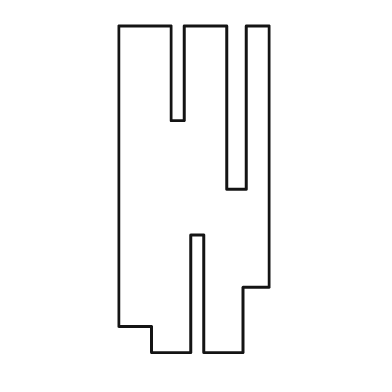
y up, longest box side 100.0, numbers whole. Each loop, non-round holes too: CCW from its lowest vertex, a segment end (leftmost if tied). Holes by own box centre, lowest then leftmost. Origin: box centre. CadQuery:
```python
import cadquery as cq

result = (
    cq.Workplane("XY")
    .moveTo(-13.0, -50.0)
    .lineTo(-1.0, -50.0)
    .lineTo(-1.0, -14.0)
    .lineTo(3.0, -14.0)
    .lineTo(3.0, -50.0)
    .lineTo(15.0, -50.0)
    .lineTo(15.0, -30.0)
    .lineTo(23.0, -30.0)
    .lineTo(23.0, 50.0)
    .lineTo(16.0, 50.0)
    .lineTo(16.0, 0.0)
    .lineTo(10.0, 0.0)
    .lineTo(10.0, 50.0)
    .lineTo(-3.0, 50.0)
    .lineTo(-3.0, 21.0)
    .lineTo(-7.0, 21.0)
    .lineTo(-7.0, 50.0)
    .lineTo(-23.0, 50.0)
    .lineTo(-23.0, -42.0)
    .lineTo(-13.0, -42.0)
    .close()
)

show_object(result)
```